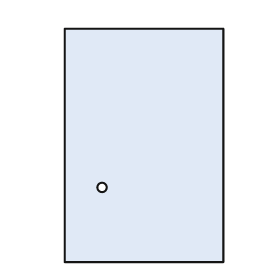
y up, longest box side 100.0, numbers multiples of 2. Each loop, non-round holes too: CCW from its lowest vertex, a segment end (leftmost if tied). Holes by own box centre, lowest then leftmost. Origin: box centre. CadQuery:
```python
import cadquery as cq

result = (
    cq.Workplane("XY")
    .moveTo(-34.0, -50.0)
    .lineTo(34.0, -50.0)
    .lineTo(34.0, 50.0)
    .lineTo(-34.0, 50.0)
    .close()
    .moveTo(-18.0, -18.0)
    .circle(2.0)
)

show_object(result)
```